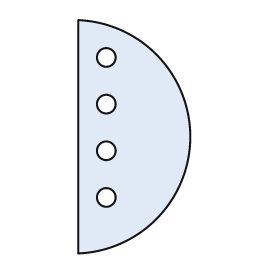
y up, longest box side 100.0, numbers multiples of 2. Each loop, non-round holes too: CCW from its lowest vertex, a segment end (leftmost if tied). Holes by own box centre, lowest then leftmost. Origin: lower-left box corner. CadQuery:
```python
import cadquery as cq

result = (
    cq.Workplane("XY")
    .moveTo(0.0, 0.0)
    .threePointArc((48.0, 50.0), (0.0, 100.0))
    .close()
    .moveTo(12.0, 24.0)
    .circle(4.0)
    .moveTo(12.0, 44.0)
    .circle(4.0)
    .moveTo(12.0, 64.0)
    .circle(4.0)
    .moveTo(12.0, 84.0)
    .circle(4.0)
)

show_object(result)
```